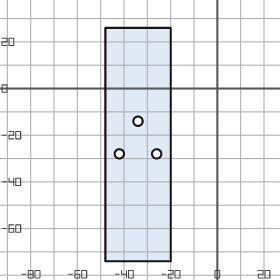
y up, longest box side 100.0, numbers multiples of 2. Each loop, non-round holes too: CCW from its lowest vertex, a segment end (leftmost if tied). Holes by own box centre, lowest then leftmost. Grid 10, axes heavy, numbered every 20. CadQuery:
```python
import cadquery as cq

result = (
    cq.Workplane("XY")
    .moveTo(-48.0, -74.0)
    .lineTo(-20.0, -74.0)
    .lineTo(-20.0, 26.0)
    .lineTo(-48.0, 26.0)
    .close()
    .moveTo(-42.0, -28.0)
    .circle(2.0)
    .moveTo(-26.0, -28.0)
    .circle(2.0)
    .moveTo(-34.0, -14.0)
    .circle(2.0)
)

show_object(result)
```